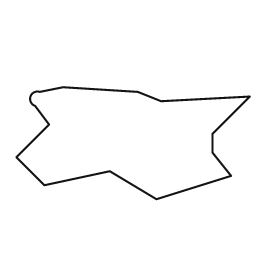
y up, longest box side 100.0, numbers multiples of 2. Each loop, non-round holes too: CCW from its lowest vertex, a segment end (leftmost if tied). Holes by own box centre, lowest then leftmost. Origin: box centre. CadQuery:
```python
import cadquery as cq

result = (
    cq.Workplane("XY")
    .moveTo(10.0, -24.0)
    .lineTo(42.0, -14.0)
    .lineTo(34.0, -4.0)
    .lineTo(34.0, 4.0)
    .lineTo(50.0, 20.0)
    .lineTo(12.0, 18.0)
    .lineTo(2.0, 22.0)
    .lineTo(-30.0, 24.0)
    .lineTo(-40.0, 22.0)
    .threePointArc((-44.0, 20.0), (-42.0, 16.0))
    .lineTo(-36.0, 8.0)
    .lineTo(-50.0, -6.0)
    .lineTo(-38.0, -18.0)
    .lineTo(-10.0, -12.0)
    .close()
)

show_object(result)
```